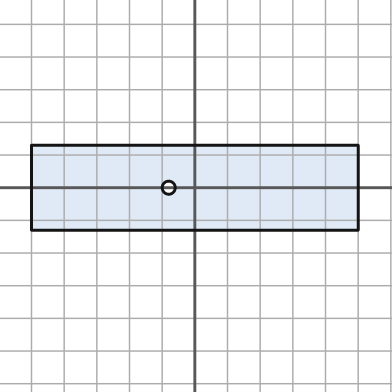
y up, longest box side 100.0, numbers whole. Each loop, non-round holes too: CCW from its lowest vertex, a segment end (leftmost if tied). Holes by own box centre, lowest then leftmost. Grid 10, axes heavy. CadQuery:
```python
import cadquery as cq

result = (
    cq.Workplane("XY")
    .moveTo(-50.0, -13.0)
    .lineTo(50.0, -13.0)
    .lineTo(50.0, 13.0)
    .lineTo(-50.0, 13.0)
    .close()
    .moveTo(-8.0, 0.0)
    .circle(2.0)
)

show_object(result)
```